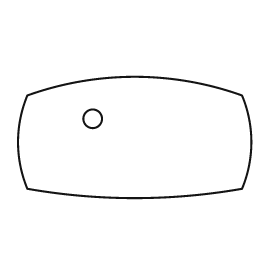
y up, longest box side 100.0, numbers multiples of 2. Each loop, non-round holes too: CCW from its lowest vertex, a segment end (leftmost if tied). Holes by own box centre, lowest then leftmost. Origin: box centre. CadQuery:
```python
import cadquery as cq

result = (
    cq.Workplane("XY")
    .moveTo(-46.0, -22.0)
    .threePointArc((0.0, -26.0), (46.0, -22.0))
    .threePointArc((50.0, -2.0), (46.0, 18.0))
    .threePointArc((0.0, 26.0), (-46.0, 18.0))
    .threePointArc((-50.0, -2.0), (-46.0, -22.0))
    .close()
    .moveTo(-18.0, 8.0)
    .circle(4.0)
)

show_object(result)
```